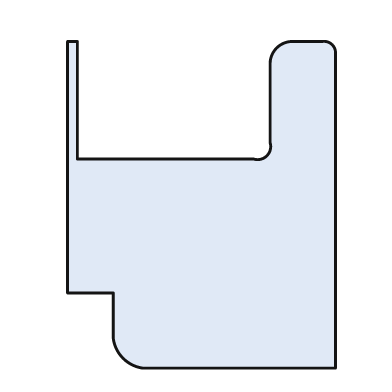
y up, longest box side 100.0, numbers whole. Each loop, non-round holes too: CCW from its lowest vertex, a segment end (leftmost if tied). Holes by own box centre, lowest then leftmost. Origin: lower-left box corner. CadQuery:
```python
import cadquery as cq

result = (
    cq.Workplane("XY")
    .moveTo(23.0, 0.0)
    .lineTo(82.0, 0.0)
    .lineTo(82.0, 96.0)
    .threePointArc((81.0, 99.0), (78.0, 100.0))
    .lineTo(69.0, 100.0)
    .threePointArc((64.0, 98.0), (62.0, 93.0))
    .lineTo(62.0, 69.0)
    .threePointArc((61.0, 65.0), (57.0, 64.0))
    .lineTo(3.0, 64.0)
    .lineTo(3.0, 100.0)
    .lineTo(0.0, 100.0)
    .lineTo(0.0, 23.0)
    .lineTo(14.0, 23.0)
    .lineTo(14.0, 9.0)
    .threePointArc((17.0, 3.0), (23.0, 0.0))
    .close()
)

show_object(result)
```